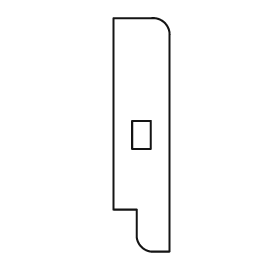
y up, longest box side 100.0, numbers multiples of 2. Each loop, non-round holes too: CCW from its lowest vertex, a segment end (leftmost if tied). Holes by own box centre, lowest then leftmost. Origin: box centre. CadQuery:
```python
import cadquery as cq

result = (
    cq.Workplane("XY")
    .moveTo(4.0, -50.0)
    .lineTo(12.0, -50.0)
    .lineTo(12.0, 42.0)
    .threePointArc((10.0, 48.0), (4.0, 50.0))
    .lineTo(-12.0, 50.0)
    .lineTo(-12.0, -32.0)
    .lineTo(-2.0, -32.0)
    .lineTo(-2.0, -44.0)
    .threePointArc((0.0, -48.0), (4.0, -50.0))
    .close()
    .moveTo(-4.0, -6.0)
    .lineTo(4.0, -6.0)
    .lineTo(4.0, 6.0)
    .lineTo(-4.0, 6.0)
    .close()
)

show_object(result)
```